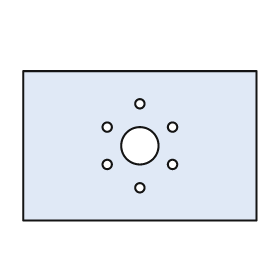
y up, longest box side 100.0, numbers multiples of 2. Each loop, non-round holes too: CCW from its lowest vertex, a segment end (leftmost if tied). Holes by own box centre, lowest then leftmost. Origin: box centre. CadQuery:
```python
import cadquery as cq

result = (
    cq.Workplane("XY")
    .moveTo(-50.0, -32.0)
    .lineTo(50.0, -32.0)
    .lineTo(50.0, 32.0)
    .lineTo(-50.0, 32.0)
    .close()
    .moveTo(0.0, -18.0)
    .circle(2.0)
    .moveTo(-14.0, -8.0)
    .circle(2.0)
    .moveTo(14.0, -8.0)
    .circle(2.0)
    .moveTo(0.0, 0.0)
    .circle(8.0)
    .moveTo(-14.0, 8.0)
    .circle(2.0)
    .moveTo(14.0, 8.0)
    .circle(2.0)
    .moveTo(0.0, 18.0)
    .circle(2.0)
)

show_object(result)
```